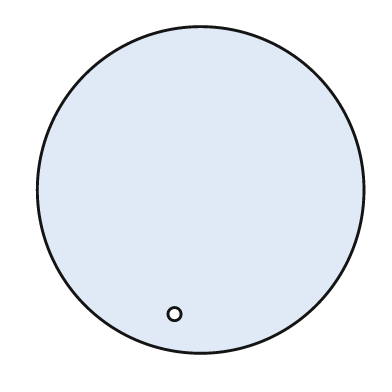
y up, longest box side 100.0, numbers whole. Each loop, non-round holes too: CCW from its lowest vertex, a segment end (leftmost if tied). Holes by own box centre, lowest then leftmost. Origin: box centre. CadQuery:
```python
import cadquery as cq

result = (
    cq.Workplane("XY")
    .moveTo(0.0, 0.0)
    .circle(50.0)
    .moveTo(-8.0, -38.0)
    .circle(2.0)
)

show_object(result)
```